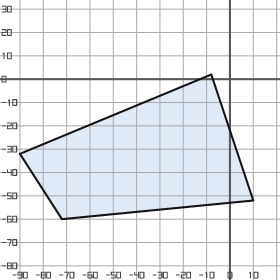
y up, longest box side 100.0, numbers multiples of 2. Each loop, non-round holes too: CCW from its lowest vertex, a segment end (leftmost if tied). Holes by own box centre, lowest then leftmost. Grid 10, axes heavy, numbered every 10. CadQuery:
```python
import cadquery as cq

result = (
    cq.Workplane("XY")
    .moveTo(-72.0, -60.0)
    .lineTo(10.0, -52.0)
    .lineTo(-8.0, 2.0)
    .lineTo(-90.0, -32.0)
    .close()
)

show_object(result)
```